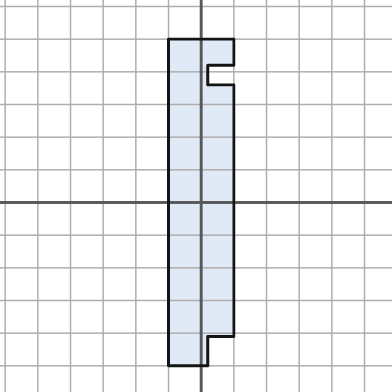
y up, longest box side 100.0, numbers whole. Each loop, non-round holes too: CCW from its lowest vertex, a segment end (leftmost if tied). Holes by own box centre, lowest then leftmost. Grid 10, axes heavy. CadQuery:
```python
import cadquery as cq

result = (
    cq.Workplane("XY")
    .moveTo(-10.0, -50.0)
    .lineTo(2.0, -50.0)
    .lineTo(2.0, -41.0)
    .lineTo(10.0, -41.0)
    .lineTo(10.0, 36.0)
    .lineTo(2.0, 36.0)
    .lineTo(2.0, 42.0)
    .lineTo(10.0, 42.0)
    .lineTo(10.0, 50.0)
    .lineTo(-10.0, 50.0)
    .close()
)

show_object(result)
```